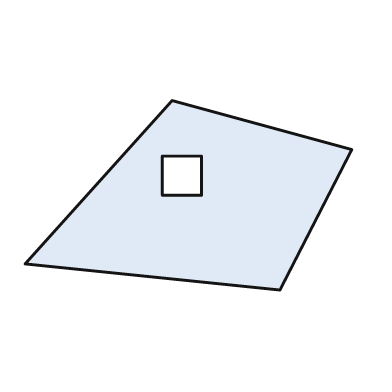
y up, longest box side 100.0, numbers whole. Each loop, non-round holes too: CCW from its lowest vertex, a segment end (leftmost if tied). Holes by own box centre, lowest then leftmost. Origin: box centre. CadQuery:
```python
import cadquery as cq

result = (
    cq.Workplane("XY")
    .moveTo(28.0, -29.0)
    .lineTo(50.0, 14.0)
    .lineTo(-5.0, 29.0)
    .lineTo(-50.0, -21.0)
    .close()
    .moveTo(-8.0, 0.0)
    .lineTo(4.0, 0.0)
    .lineTo(4.0, 12.0)
    .lineTo(-8.0, 12.0)
    .close()
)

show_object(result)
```